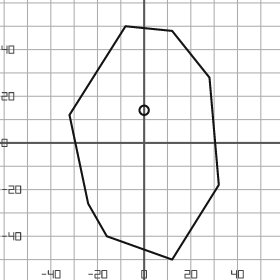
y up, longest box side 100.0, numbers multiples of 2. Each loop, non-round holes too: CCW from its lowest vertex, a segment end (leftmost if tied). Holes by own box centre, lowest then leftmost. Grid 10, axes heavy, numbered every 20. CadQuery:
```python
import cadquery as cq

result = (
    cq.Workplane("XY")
    .moveTo(12.0, -50.0)
    .lineTo(32.0, -18.0)
    .lineTo(28.0, 28.0)
    .lineTo(12.0, 48.0)
    .lineTo(-8.0, 50.0)
    .lineTo(-32.0, 12.0)
    .lineTo(-24.0, -26.0)
    .lineTo(-16.0, -40.0)
    .close()
    .moveTo(0.0, 14.0)
    .circle(2.0)
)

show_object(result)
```